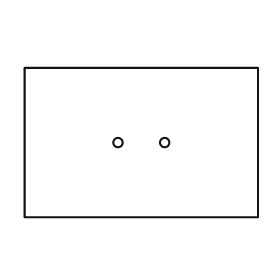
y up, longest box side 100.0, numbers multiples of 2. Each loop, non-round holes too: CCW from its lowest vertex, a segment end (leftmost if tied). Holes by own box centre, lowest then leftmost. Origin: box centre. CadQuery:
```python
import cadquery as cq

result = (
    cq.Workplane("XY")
    .moveTo(-50.0, -32.0)
    .lineTo(50.0, -32.0)
    .lineTo(50.0, 32.0)
    .lineTo(-50.0, 32.0)
    .close()
    .moveTo(-10.0, 0.0)
    .circle(2.0)
    .moveTo(10.0, 0.0)
    .circle(2.0)
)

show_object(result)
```